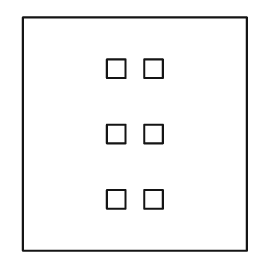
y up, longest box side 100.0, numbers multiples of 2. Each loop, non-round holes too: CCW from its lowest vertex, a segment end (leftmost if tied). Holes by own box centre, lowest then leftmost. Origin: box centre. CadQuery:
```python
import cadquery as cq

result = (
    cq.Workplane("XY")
    .moveTo(-48.0, -50.0)
    .lineTo(48.0, -50.0)
    .lineTo(48.0, 50.0)
    .lineTo(-48.0, 50.0)
    .close()
    .moveTo(-12.0, -32.0)
    .lineTo(-4.0, -32.0)
    .lineTo(-4.0, -24.0)
    .lineTo(-12.0, -24.0)
    .close()
    .moveTo(4.0, -32.0)
    .lineTo(12.0, -32.0)
    .lineTo(12.0, -24.0)
    .lineTo(4.0, -24.0)
    .close()
    .moveTo(-12.0, -4.0)
    .lineTo(-4.0, -4.0)
    .lineTo(-4.0, 4.0)
    .lineTo(-12.0, 4.0)
    .close()
    .moveTo(4.0, -4.0)
    .lineTo(12.0, -4.0)
    .lineTo(12.0, 4.0)
    .lineTo(4.0, 4.0)
    .close()
    .moveTo(-12.0, 24.0)
    .lineTo(-4.0, 24.0)
    .lineTo(-4.0, 32.0)
    .lineTo(-12.0, 32.0)
    .close()
    .moveTo(4.0, 24.0)
    .lineTo(12.0, 24.0)
    .lineTo(12.0, 32.0)
    .lineTo(4.0, 32.0)
    .close()
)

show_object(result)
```